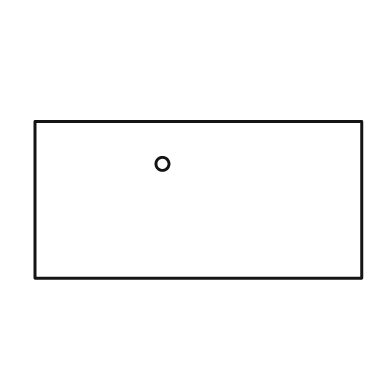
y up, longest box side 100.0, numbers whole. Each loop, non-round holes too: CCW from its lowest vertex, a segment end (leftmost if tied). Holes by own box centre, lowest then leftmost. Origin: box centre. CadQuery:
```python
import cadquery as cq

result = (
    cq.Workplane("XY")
    .moveTo(-50.0, -24.0)
    .lineTo(50.0, -24.0)
    .lineTo(50.0, 24.0)
    .lineTo(-50.0, 24.0)
    .close()
    .moveTo(-11.0, 11.0)
    .circle(2.0)
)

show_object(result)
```